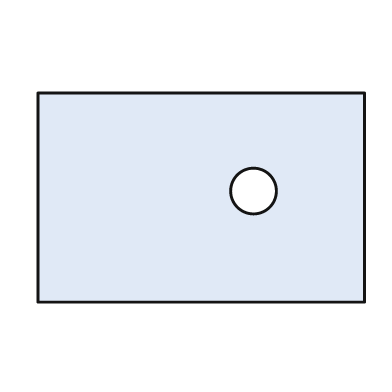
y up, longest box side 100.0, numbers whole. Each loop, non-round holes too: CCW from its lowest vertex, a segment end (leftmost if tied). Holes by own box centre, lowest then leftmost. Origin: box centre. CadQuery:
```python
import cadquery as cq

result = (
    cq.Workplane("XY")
    .moveTo(-50.0, -32.0)
    .lineTo(50.0, -32.0)
    .lineTo(50.0, 32.0)
    .lineTo(-50.0, 32.0)
    .close()
    .moveTo(16.0, 2.0)
    .circle(7.0)
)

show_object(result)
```